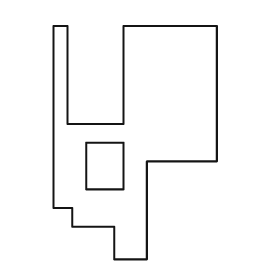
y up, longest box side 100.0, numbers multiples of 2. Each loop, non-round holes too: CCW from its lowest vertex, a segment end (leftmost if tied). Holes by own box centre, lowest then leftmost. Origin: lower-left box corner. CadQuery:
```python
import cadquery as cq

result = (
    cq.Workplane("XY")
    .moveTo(26.0, 0.0)
    .lineTo(40.0, 0.0)
    .lineTo(40.0, 42.0)
    .lineTo(70.0, 42.0)
    .lineTo(70.0, 100.0)
    .lineTo(30.0, 100.0)
    .lineTo(30.0, 58.0)
    .lineTo(6.0, 58.0)
    .lineTo(6.0, 100.0)
    .lineTo(0.0, 100.0)
    .lineTo(0.0, 22.0)
    .lineTo(8.0, 22.0)
    .lineTo(8.0, 14.0)
    .lineTo(26.0, 14.0)
    .close()
    .moveTo(14.0, 30.0)
    .lineTo(30.0, 30.0)
    .lineTo(30.0, 50.0)
    .lineTo(14.0, 50.0)
    .close()
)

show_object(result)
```